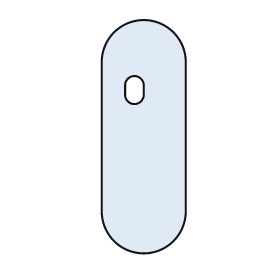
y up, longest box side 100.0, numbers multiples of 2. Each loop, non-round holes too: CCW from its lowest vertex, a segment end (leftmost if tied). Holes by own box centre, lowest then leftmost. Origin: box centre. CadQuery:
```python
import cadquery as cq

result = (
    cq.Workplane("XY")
    .moveTo(-18.0, -32.0)
    .threePointArc((0.0, -50.0), (18.0, -32.0))
    .lineTo(18.0, 32.0)
    .threePointArc((0.0, 50.0), (-18.0, 32.0))
    .close()
    .moveTo(-8.0, 18.0)
    .threePointArc((-4.0, 14.0), (0.0, 18.0))
    .lineTo(0.0, 22.0)
    .threePointArc((-4.0, 26.0), (-8.0, 22.0))
    .close()
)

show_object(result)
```